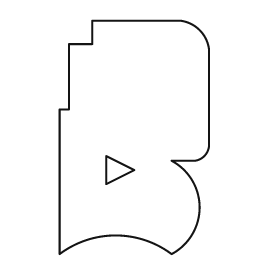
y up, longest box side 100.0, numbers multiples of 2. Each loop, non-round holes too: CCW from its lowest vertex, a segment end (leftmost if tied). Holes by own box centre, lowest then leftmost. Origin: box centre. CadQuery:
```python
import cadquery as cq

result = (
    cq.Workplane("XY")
    .moveTo(-32.0, -50.0)
    .threePointArc((-8.0, -42.0), (16.0, -50.0))
    .threePointArc((28.0, -30.0), (16.0, -10.0))
    .lineTo(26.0, -10.0)
    .threePointArc((30.0, -8.0), (32.0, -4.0))
    .lineTo(32.0, 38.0)
    .threePointArc((28.0, 46.0), (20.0, 50.0))
    .lineTo(-18.0, 50.0)
    .lineTo(-18.0, 40.0)
    .lineTo(-28.0, 40.0)
    .lineTo(-28.0, 12.0)
    .lineTo(-32.0, 12.0)
    .close()
    .moveTo(-12.0, -20.0)
    .lineTo(0.0, -14.0)
    .lineTo(-12.0, -8.0)
    .close()
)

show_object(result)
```